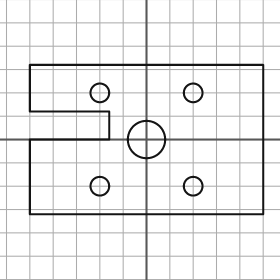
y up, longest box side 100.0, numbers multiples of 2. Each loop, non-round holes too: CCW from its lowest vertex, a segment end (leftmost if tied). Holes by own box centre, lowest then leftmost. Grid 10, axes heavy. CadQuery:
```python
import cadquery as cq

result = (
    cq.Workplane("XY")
    .moveTo(-50.0, -32.0)
    .lineTo(50.0, -32.0)
    .lineTo(50.0, 32.0)
    .lineTo(-50.0, 32.0)
    .lineTo(-50.0, 12.0)
    .lineTo(-16.0, 12.0)
    .lineTo(-16.0, 0.0)
    .lineTo(-50.0, 0.0)
    .close()
    .moveTo(-20.0, -20.0)
    .circle(4.0)
    .moveTo(20.0, -20.0)
    .circle(4.0)
    .moveTo(0.0, 0.0)
    .circle(8.0)
    .moveTo(-20.0, 20.0)
    .circle(4.0)
    .moveTo(20.0, 20.0)
    .circle(4.0)
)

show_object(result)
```